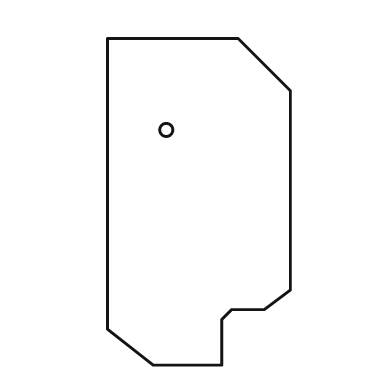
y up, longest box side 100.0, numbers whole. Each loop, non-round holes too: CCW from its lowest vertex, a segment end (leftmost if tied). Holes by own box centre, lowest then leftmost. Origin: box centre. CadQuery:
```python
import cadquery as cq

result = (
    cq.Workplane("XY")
    .moveTo(-14.0, -50.0)
    .lineTo(7.0, -50.0)
    .lineTo(7.0, -36.0)
    .lineTo(10.0, -33.0)
    .lineTo(20.0, -33.0)
    .lineTo(28.0, -27.0)
    .lineTo(28.0, 34.0)
    .lineTo(12.0, 50.0)
    .lineTo(-28.0, 50.0)
    .lineTo(-28.0, -39.0)
    .close()
    .moveTo(-10.0, 22.0)
    .circle(2.0)
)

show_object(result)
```